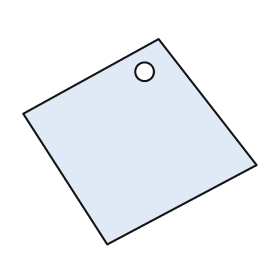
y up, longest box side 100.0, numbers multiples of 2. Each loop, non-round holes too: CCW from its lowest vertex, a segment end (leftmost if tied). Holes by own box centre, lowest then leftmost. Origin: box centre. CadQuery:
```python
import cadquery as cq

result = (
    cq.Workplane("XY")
    .moveTo(-14.0, -44.0)
    .lineTo(50.0, -10.0)
    .lineTo(8.0, 44.0)
    .lineTo(-50.0, 12.0)
    .close()
    .moveTo(2.0, 30.0)
    .circle(4.0)
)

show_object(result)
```